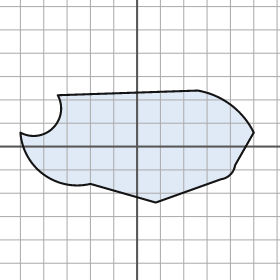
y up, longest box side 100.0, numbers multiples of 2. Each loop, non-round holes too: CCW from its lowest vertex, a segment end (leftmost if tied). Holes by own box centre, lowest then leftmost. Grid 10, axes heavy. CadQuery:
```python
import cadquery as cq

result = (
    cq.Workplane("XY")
    .moveTo(8.0, -24.0)
    .lineTo(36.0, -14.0)
    .threePointArc((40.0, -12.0), (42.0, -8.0))
    .lineTo(50.0, 6.0)
    .threePointArc((40.0, 18.0), (26.0, 24.0))
    .lineTo(-34.0, 22.0)
    .threePointArc((-36.0, 8.0), (-50.0, 6.0))
    .threePointArc((-40.0, -12.0), (-20.0, -16.0))
    .close()
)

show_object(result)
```